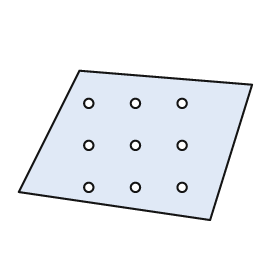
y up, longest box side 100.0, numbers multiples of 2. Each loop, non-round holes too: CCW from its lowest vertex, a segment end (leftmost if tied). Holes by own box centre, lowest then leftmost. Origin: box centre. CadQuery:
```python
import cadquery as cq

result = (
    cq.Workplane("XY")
    .moveTo(32.0, -32.0)
    .lineTo(50.0, 26.0)
    .lineTo(-24.0, 32.0)
    .lineTo(-50.0, -20.0)
    .close()
    .moveTo(-20.0, -18.0)
    .circle(2.0)
    .moveTo(0.0, -18.0)
    .circle(2.0)
    .moveTo(20.0, -18.0)
    .circle(2.0)
    .moveTo(-20.0, 0.0)
    .circle(2.0)
    .moveTo(0.0, 0.0)
    .circle(2.0)
    .moveTo(20.0, 0.0)
    .circle(2.0)
    .moveTo(-20.0, 18.0)
    .circle(2.0)
    .moveTo(0.0, 18.0)
    .circle(2.0)
    .moveTo(20.0, 18.0)
    .circle(2.0)
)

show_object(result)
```